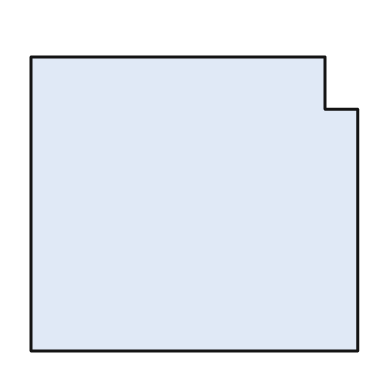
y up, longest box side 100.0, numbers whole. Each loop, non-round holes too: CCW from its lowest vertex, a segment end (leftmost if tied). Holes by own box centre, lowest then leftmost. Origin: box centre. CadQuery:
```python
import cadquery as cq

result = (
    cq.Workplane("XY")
    .moveTo(-50.0, -45.0)
    .lineTo(50.0, -45.0)
    .lineTo(50.0, 29.0)
    .lineTo(40.0, 29.0)
    .lineTo(40.0, 45.0)
    .lineTo(-50.0, 45.0)
    .close()
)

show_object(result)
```